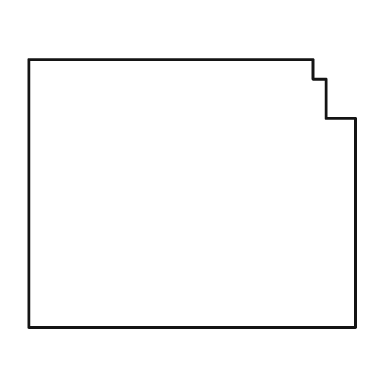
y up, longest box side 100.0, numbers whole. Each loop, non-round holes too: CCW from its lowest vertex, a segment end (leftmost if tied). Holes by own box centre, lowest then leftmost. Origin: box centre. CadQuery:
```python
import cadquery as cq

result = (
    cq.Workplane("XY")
    .moveTo(-50.0, -41.0)
    .lineTo(50.0, -41.0)
    .lineTo(50.0, 23.0)
    .lineTo(41.0, 23.0)
    .lineTo(41.0, 35.0)
    .lineTo(37.0, 35.0)
    .lineTo(37.0, 41.0)
    .lineTo(-50.0, 41.0)
    .close()
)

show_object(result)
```